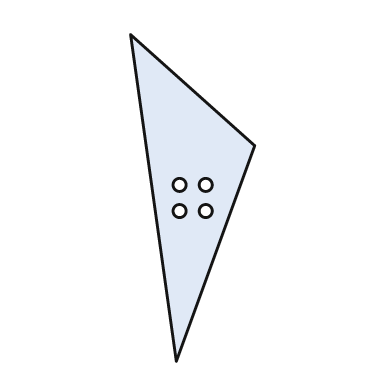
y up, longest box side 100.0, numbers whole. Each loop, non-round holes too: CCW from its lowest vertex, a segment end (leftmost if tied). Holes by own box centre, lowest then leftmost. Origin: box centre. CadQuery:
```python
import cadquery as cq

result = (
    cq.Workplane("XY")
    .moveTo(-5.0, -50.0)
    .lineTo(19.0, 16.0)
    .lineTo(-19.0, 50.0)
    .close()
    .moveTo(-4.0, -4.0)
    .circle(2.0)
    .moveTo(4.0, -4.0)
    .circle(2.0)
    .moveTo(-4.0, 4.0)
    .circle(2.0)
    .moveTo(4.0, 4.0)
    .circle(2.0)
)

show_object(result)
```